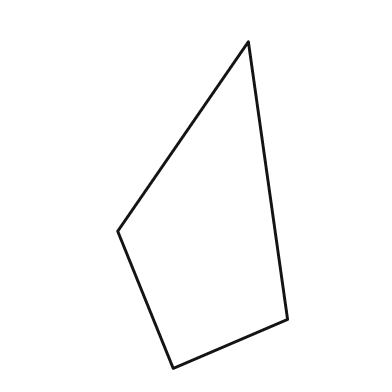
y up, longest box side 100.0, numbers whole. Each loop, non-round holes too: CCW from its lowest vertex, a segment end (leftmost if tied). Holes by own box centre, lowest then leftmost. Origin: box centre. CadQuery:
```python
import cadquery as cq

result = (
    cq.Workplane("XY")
    .moveTo(-9.0, -50.0)
    .lineTo(26.0, -35.0)
    .lineTo(14.0, 50.0)
    .lineTo(-26.0, -8.0)
    .close()
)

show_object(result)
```